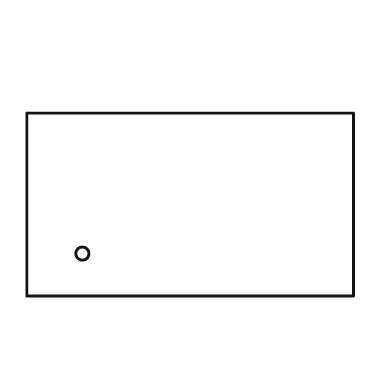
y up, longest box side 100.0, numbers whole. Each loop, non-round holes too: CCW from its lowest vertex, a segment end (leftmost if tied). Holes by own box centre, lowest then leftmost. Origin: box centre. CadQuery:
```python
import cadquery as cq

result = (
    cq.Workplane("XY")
    .moveTo(-50.0, -28.0)
    .lineTo(50.0, -28.0)
    .lineTo(50.0, 28.0)
    .lineTo(-50.0, 28.0)
    .close()
    .moveTo(-33.0, -15.0)
    .circle(2.0)
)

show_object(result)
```